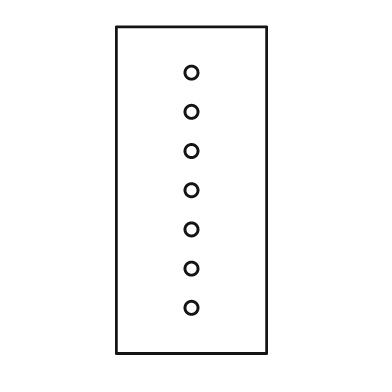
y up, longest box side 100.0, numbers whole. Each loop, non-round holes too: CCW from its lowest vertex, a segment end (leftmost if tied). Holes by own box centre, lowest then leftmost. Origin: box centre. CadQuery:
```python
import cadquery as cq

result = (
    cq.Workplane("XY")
    .moveTo(-23.0, -50.0)
    .lineTo(23.0, -50.0)
    .lineTo(23.0, 50.0)
    .lineTo(-23.0, 50.0)
    .close()
    .moveTo(0.0, -36.0)
    .circle(2.0)
    .moveTo(0.0, -24.0)
    .circle(2.0)
    .moveTo(0.0, -12.0)
    .circle(2.0)
    .moveTo(0.0, 0.0)
    .circle(2.0)
    .moveTo(0.0, 12.0)
    .circle(2.0)
    .moveTo(0.0, 24.0)
    .circle(2.0)
    .moveTo(0.0, 36.0)
    .circle(2.0)
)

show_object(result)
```